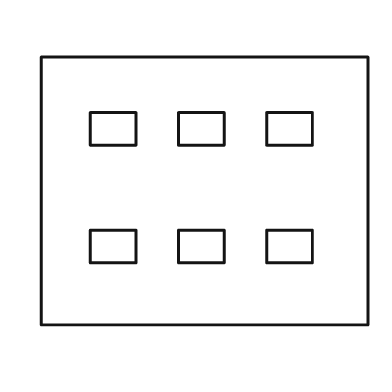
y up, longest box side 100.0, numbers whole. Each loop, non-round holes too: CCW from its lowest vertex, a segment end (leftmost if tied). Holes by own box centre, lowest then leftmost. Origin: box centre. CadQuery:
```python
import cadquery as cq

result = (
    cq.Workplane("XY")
    .moveTo(-50.0, -41.0)
    .lineTo(50.0, -41.0)
    .lineTo(50.0, 41.0)
    .lineTo(-50.0, 41.0)
    .close()
    .moveTo(-35.0, -22.0)
    .lineTo(-21.0, -22.0)
    .lineTo(-21.0, -12.0)
    .lineTo(-35.0, -12.0)
    .close()
    .moveTo(-8.0, -22.0)
    .lineTo(6.0, -22.0)
    .lineTo(6.0, -12.0)
    .lineTo(-8.0, -12.0)
    .close()
    .moveTo(19.0, -22.0)
    .lineTo(33.0, -22.0)
    .lineTo(33.0, -12.0)
    .lineTo(19.0, -12.0)
    .close()
    .moveTo(-35.0, 14.0)
    .lineTo(-21.0, 14.0)
    .lineTo(-21.0, 24.0)
    .lineTo(-35.0, 24.0)
    .close()
    .moveTo(-8.0, 14.0)
    .lineTo(6.0, 14.0)
    .lineTo(6.0, 24.0)
    .lineTo(-8.0, 24.0)
    .close()
    .moveTo(19.0, 14.0)
    .lineTo(33.0, 14.0)
    .lineTo(33.0, 24.0)
    .lineTo(19.0, 24.0)
    .close()
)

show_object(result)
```